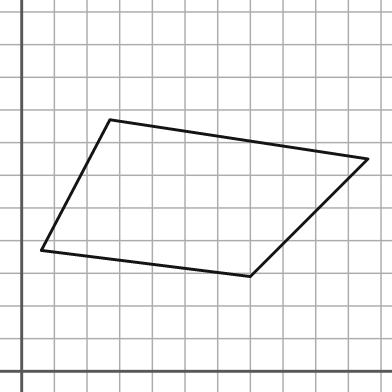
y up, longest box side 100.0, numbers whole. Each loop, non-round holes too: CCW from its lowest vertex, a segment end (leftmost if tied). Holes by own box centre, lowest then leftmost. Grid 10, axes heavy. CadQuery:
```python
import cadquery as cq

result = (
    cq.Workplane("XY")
    .moveTo(70.0, 29.0)
    .lineTo(106.0, 65.0)
    .lineTo(27.0, 77.0)
    .lineTo(6.0, 37.0)
    .close()
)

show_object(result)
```